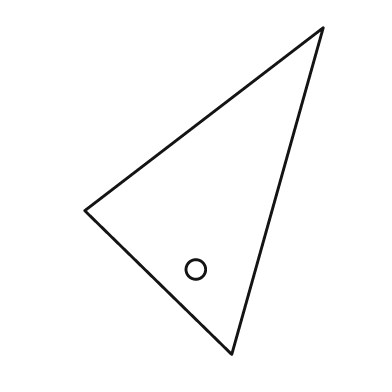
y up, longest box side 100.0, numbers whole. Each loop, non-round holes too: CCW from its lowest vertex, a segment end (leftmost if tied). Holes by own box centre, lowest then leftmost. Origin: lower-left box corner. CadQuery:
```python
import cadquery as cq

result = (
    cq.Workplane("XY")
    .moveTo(45.0, 0.0)
    .lineTo(73.0, 100.0)
    .lineTo(0.0, 44.0)
    .close()
    .moveTo(34.0, 26.0)
    .circle(3.0)
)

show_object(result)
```